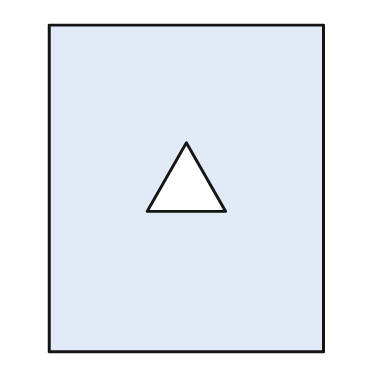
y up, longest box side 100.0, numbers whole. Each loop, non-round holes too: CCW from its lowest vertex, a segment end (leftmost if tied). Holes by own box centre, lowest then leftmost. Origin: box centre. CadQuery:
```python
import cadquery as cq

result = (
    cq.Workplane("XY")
    .moveTo(-42.0, -50.0)
    .lineTo(42.0, -50.0)
    .lineTo(42.0, 50.0)
    .lineTo(-42.0, 50.0)
    .close()
    .moveTo(-12.0, -7.0)
    .lineTo(12.0, -7.0)
    .lineTo(0.0, 14.0)
    .close()
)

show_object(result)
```